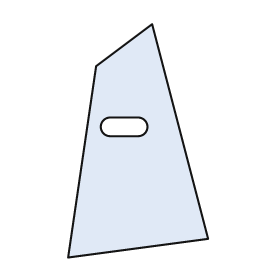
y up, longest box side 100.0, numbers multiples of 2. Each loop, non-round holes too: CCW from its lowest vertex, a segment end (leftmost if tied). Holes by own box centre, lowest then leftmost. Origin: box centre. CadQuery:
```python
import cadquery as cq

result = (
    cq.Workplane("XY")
    .moveTo(-30.0, -50.0)
    .lineTo(30.0, -42.0)
    .lineTo(6.0, 50.0)
    .lineTo(-18.0, 32.0)
    .close()
    .moveTo(-12.0, 2.0)
    .lineTo(0.0, 2.0)
    .threePointArc((4.0, 6.0), (0.0, 10.0))
    .lineTo(-12.0, 10.0)
    .threePointArc((-16.0, 6.0), (-12.0, 2.0))
    .close()
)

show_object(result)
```